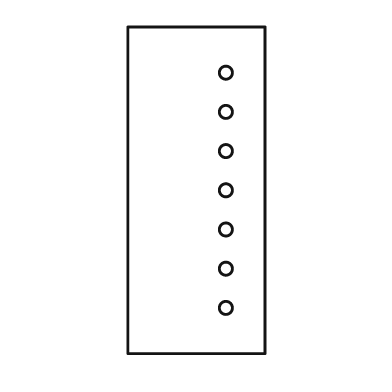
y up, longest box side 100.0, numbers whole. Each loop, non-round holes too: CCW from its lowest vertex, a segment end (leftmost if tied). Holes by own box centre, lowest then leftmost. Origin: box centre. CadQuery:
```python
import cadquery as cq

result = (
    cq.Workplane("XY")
    .moveTo(-21.0, -50.0)
    .lineTo(21.0, -50.0)
    .lineTo(21.0, 50.0)
    .lineTo(-21.0, 50.0)
    .close()
    .moveTo(9.0, -36.0)
    .circle(2.0)
    .moveTo(9.0, -24.0)
    .circle(2.0)
    .moveTo(9.0, -12.0)
    .circle(2.0)
    .moveTo(9.0, 0.0)
    .circle(2.0)
    .moveTo(9.0, 12.0)
    .circle(2.0)
    .moveTo(9.0, 24.0)
    .circle(2.0)
    .moveTo(9.0, 36.0)
    .circle(2.0)
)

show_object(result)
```